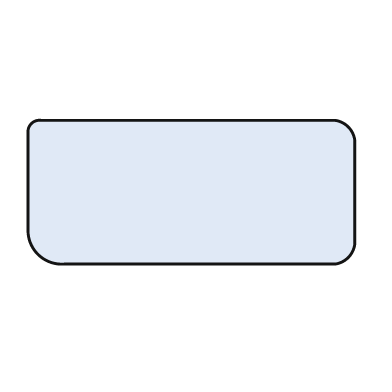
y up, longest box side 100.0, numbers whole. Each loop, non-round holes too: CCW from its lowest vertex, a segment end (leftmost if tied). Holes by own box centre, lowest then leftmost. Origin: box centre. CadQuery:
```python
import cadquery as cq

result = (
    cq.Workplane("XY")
    .moveTo(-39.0, -22.0)
    .lineTo(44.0, -22.0)
    .threePointArc((48.0, -20.0), (50.0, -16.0))
    .lineTo(50.0, 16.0)
    .threePointArc((48.0, 20.0), (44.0, 22.0))
    .lineTo(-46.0, 22.0)
    .threePointArc((-49.0, 21.0), (-50.0, 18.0))
    .lineTo(-50.0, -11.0)
    .threePointArc((-47.0, -19.0), (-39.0, -22.0))
    .close()
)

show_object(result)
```